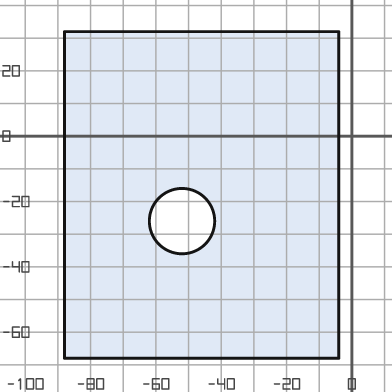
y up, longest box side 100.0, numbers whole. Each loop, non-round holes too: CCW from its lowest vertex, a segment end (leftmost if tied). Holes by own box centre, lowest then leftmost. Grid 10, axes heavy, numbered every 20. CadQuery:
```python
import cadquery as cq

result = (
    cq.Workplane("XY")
    .moveTo(-88.0, -68.0)
    .lineTo(-4.0, -68.0)
    .lineTo(-4.0, 32.0)
    .lineTo(-88.0, 32.0)
    .close()
    .moveTo(-52.0, -26.0)
    .circle(10.0)
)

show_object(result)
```